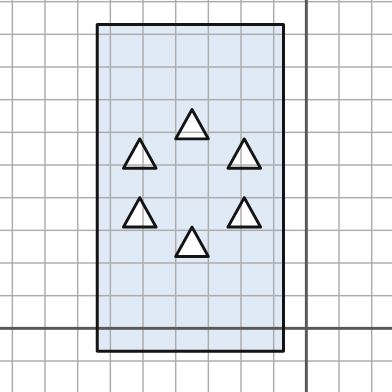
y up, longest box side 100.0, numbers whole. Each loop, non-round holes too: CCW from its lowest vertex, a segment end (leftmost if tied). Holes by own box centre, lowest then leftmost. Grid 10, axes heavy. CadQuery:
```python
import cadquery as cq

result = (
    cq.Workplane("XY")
    .moveTo(-64.0, -7.0)
    .lineTo(-7.0, -7.0)
    .lineTo(-7.0, 93.0)
    .lineTo(-64.0, 93.0)
    .close()
    .moveTo(-40.0, 22.0)
    .lineTo(-30.0, 22.0)
    .lineTo(-35.0, 31.0)
    .close()
    .moveTo(-56.0, 31.0)
    .lineTo(-46.0, 31.0)
    .lineTo(-51.0, 40.0)
    .close()
    .moveTo(-24.0, 31.0)
    .lineTo(-14.0, 31.0)
    .lineTo(-19.0, 40.0)
    .close()
    .moveTo(-56.0, 49.0)
    .lineTo(-46.0, 49.0)
    .lineTo(-51.0, 58.0)
    .close()
    .moveTo(-24.0, 49.0)
    .lineTo(-14.0, 49.0)
    .lineTo(-19.0, 58.0)
    .close()
    .moveTo(-40.0, 58.0)
    .lineTo(-30.0, 58.0)
    .lineTo(-35.0, 67.0)
    .close()
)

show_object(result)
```